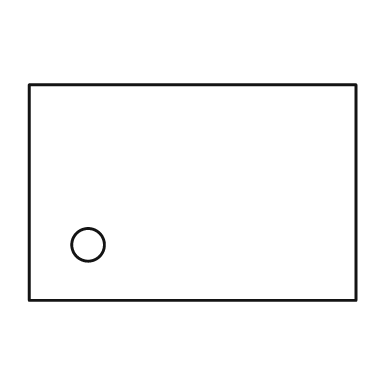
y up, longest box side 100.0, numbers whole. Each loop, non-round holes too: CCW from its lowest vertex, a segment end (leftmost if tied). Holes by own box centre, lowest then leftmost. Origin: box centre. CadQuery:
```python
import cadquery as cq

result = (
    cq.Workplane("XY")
    .moveTo(-50.0, -33.0)
    .lineTo(50.0, -33.0)
    .lineTo(50.0, 33.0)
    .lineTo(-50.0, 33.0)
    .close()
    .moveTo(-32.0, -16.0)
    .circle(5.0)
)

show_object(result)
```